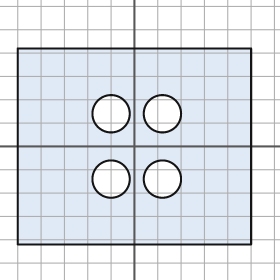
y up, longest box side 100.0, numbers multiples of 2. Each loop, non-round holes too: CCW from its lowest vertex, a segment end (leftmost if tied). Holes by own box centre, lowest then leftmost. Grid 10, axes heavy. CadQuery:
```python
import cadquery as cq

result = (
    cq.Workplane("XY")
    .moveTo(-50.0, -42.0)
    .lineTo(50.0, -42.0)
    .lineTo(50.0, 42.0)
    .lineTo(-50.0, 42.0)
    .close()
    .moveTo(-10.0, -14.0)
    .circle(8.0)
    .moveTo(12.0, -14.0)
    .circle(8.0)
    .moveTo(-10.0, 14.0)
    .circle(8.0)
    .moveTo(12.0, 14.0)
    .circle(8.0)
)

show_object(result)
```